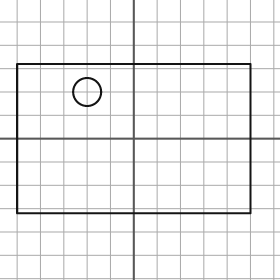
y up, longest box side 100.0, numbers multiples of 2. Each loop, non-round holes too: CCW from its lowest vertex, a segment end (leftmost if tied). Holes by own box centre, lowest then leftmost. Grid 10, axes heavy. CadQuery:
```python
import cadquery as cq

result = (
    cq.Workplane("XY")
    .moveTo(-50.0, -32.0)
    .lineTo(50.0, -32.0)
    .lineTo(50.0, 32.0)
    .lineTo(-50.0, 32.0)
    .close()
    .moveTo(-20.0, 20.0)
    .circle(6.0)
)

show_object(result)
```